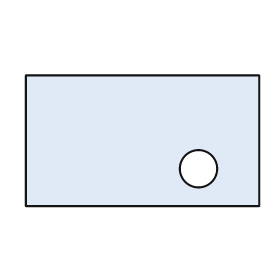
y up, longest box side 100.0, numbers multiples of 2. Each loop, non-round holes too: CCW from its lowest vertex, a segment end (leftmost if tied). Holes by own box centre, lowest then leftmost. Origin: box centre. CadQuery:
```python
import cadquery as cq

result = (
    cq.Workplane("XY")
    .moveTo(-50.0, -28.0)
    .lineTo(50.0, -28.0)
    .lineTo(50.0, 28.0)
    .lineTo(-50.0, 28.0)
    .close()
    .moveTo(24.0, -12.0)
    .circle(8.0)
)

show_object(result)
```